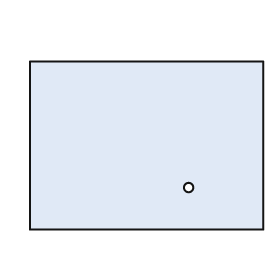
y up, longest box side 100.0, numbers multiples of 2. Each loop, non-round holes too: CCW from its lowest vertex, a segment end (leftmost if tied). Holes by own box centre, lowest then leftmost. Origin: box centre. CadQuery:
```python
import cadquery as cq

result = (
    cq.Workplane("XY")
    .moveTo(-50.0, -36.0)
    .lineTo(50.0, -36.0)
    .lineTo(50.0, 36.0)
    .lineTo(-50.0, 36.0)
    .close()
    .moveTo(18.0, -18.0)
    .circle(2.0)
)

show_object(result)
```